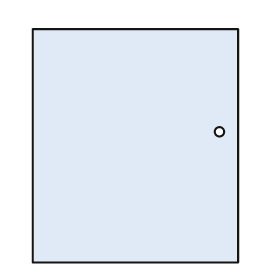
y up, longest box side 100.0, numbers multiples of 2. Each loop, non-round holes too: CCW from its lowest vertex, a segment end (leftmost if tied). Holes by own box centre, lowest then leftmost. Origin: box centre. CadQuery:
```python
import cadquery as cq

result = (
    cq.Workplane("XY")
    .moveTo(-44.0, -50.0)
    .lineTo(44.0, -50.0)
    .lineTo(44.0, 50.0)
    .lineTo(-44.0, 50.0)
    .close()
    .moveTo(36.0, 6.0)
    .circle(2.0)
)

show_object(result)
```